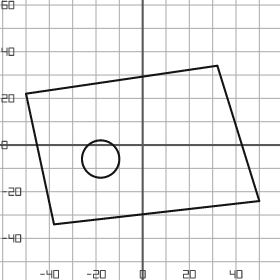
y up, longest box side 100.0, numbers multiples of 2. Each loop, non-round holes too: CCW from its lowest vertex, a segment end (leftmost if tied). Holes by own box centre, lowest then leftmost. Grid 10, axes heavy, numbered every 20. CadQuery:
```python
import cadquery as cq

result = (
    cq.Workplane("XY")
    .moveTo(-38.0, -34.0)
    .lineTo(50.0, -24.0)
    .lineTo(32.0, 34.0)
    .lineTo(-50.0, 22.0)
    .close()
    .moveTo(-18.0, -6.0)
    .circle(8.0)
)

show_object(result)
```